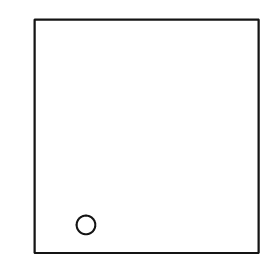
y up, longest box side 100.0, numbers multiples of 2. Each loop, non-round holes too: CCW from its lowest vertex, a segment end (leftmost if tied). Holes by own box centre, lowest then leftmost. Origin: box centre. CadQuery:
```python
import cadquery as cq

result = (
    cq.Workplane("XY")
    .moveTo(-48.0, -50.0)
    .lineTo(48.0, -50.0)
    .lineTo(48.0, 50.0)
    .lineTo(-48.0, 50.0)
    .close()
    .moveTo(-26.0, -38.0)
    .circle(4.0)
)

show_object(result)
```